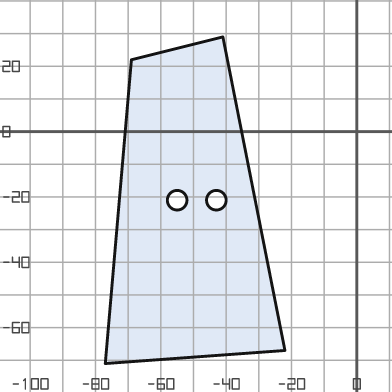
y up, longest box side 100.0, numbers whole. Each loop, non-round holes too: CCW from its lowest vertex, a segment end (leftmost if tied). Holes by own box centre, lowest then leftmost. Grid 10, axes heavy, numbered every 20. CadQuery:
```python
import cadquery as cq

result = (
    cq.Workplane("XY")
    .moveTo(-77.0, -71.0)
    .lineTo(-22.0, -67.0)
    .lineTo(-41.0, 29.0)
    .lineTo(-69.0, 22.0)
    .close()
    .moveTo(-55.0, -21.0)
    .circle(3.0)
    .moveTo(-43.0, -21.0)
    .circle(3.0)
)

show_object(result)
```